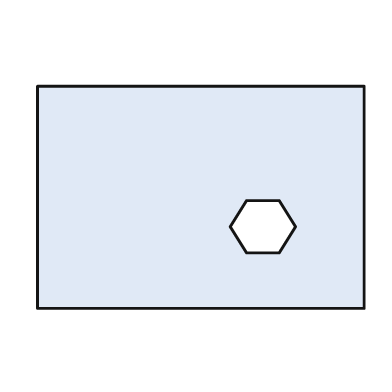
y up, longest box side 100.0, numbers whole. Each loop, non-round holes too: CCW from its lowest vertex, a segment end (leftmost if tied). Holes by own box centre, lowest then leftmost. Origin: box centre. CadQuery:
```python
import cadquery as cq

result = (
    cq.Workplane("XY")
    .moveTo(-50.0, -34.0)
    .lineTo(50.0, -34.0)
    .lineTo(50.0, 34.0)
    .lineTo(-50.0, 34.0)
    .close()
    .moveTo(14.0, -17.0)
    .lineTo(24.0, -17.0)
    .lineTo(29.0, -9.0)
    .lineTo(24.0, -1.0)
    .lineTo(14.0, -1.0)
    .lineTo(9.0, -9.0)
    .close()
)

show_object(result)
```